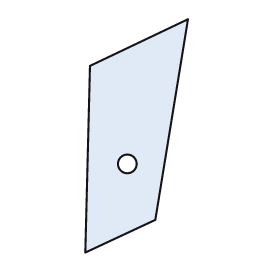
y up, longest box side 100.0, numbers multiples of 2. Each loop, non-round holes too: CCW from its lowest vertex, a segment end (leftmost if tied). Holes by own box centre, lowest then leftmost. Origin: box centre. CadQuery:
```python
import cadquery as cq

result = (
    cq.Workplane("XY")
    .moveTo(-22.0, -50.0)
    .lineTo(8.0, -36.0)
    .lineTo(22.0, 50.0)
    .lineTo(-20.0, 30.0)
    .close()
    .moveTo(-4.0, -12.0)
    .circle(4.0)
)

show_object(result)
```